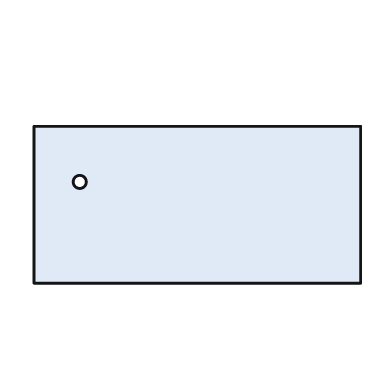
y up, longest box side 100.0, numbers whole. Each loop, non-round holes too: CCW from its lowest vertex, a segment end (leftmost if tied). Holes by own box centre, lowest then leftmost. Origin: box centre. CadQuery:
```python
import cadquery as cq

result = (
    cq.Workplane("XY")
    .moveTo(-50.0, -24.0)
    .lineTo(50.0, -24.0)
    .lineTo(50.0, 24.0)
    .lineTo(-50.0, 24.0)
    .close()
    .moveTo(-36.0, 7.0)
    .circle(2.0)
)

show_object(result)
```